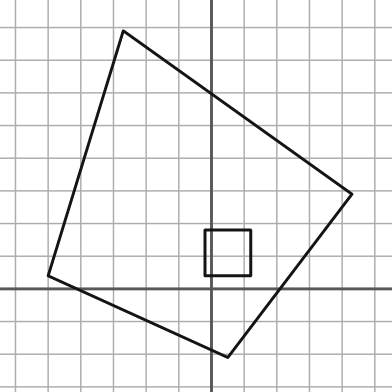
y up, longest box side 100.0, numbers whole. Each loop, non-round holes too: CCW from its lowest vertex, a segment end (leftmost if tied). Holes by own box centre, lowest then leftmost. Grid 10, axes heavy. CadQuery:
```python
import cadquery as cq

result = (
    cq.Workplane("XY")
    .moveTo(5.0, -21.0)
    .lineTo(43.0, 29.0)
    .lineTo(-27.0, 79.0)
    .lineTo(-50.0, 4.0)
    .close()
    .moveTo(-2.0, 4.0)
    .lineTo(12.0, 4.0)
    .lineTo(12.0, 18.0)
    .lineTo(-2.0, 18.0)
    .close()
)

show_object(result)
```